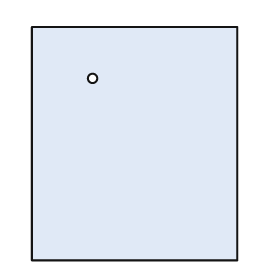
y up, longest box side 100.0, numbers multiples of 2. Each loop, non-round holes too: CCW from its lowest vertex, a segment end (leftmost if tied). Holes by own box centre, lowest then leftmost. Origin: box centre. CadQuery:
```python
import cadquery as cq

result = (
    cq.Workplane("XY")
    .moveTo(-44.0, -50.0)
    .lineTo(44.0, -50.0)
    .lineTo(44.0, 50.0)
    .lineTo(-44.0, 50.0)
    .close()
    .moveTo(-18.0, 28.0)
    .circle(2.0)
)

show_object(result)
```